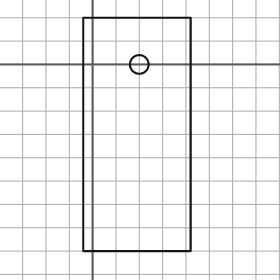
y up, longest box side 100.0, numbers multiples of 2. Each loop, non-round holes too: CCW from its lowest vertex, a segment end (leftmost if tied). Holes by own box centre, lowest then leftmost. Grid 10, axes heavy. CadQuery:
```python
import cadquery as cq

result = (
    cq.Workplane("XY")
    .moveTo(-4.0, -80.0)
    .lineTo(42.0, -80.0)
    .lineTo(42.0, 20.0)
    .lineTo(-4.0, 20.0)
    .close()
    .moveTo(20.0, 0.0)
    .circle(4.0)
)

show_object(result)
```